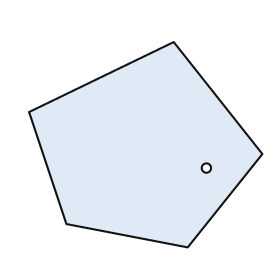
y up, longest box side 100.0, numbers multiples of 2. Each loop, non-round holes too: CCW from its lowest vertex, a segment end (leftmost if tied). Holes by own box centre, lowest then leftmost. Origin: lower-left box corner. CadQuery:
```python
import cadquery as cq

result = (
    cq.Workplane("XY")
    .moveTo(68.0, 0.0)
    .lineTo(100.0, 40.0)
    .lineTo(62.0, 88.0)
    .lineTo(0.0, 58.0)
    .lineTo(16.0, 10.0)
    .close()
    .moveTo(76.0, 34.0)
    .circle(2.0)
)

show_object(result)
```